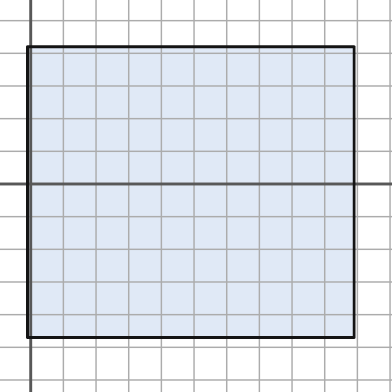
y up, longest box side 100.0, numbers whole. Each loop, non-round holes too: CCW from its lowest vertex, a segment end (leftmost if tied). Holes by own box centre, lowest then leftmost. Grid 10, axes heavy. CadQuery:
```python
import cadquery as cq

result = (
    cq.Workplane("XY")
    .moveTo(-1.0, -47.0)
    .lineTo(99.0, -47.0)
    .lineTo(99.0, 42.0)
    .lineTo(-1.0, 42.0)
    .close()
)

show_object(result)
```